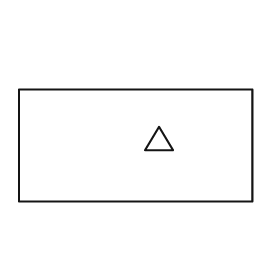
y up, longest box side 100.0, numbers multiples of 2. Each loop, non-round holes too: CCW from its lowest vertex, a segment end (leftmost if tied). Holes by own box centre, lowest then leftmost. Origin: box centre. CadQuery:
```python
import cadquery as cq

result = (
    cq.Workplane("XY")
    .moveTo(-50.0, -24.0)
    .lineTo(50.0, -24.0)
    .lineTo(50.0, 24.0)
    .lineTo(-50.0, 24.0)
    .close()
    .moveTo(4.0, -2.0)
    .lineTo(16.0, -2.0)
    .lineTo(10.0, 8.0)
    .close()
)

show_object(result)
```